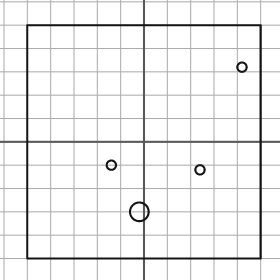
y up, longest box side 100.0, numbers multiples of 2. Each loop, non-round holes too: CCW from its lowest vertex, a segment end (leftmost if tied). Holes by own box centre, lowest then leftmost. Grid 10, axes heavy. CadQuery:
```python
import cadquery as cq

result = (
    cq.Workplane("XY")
    .moveTo(-50.0, -50.0)
    .lineTo(50.0, -50.0)
    .lineTo(50.0, 50.0)
    .lineTo(-50.0, 50.0)
    .close()
    .moveTo(-2.0, -30.0)
    .circle(4.0)
    .moveTo(24.0, -12.0)
    .circle(2.0)
    .moveTo(-14.0, -10.0)
    .circle(2.0)
    .moveTo(42.0, 32.0)
    .circle(2.0)
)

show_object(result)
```